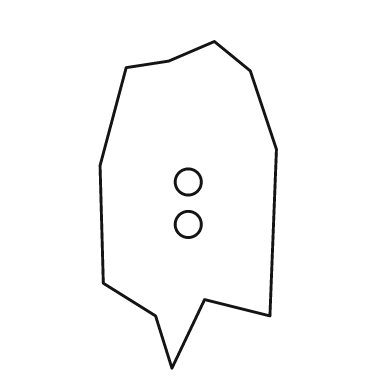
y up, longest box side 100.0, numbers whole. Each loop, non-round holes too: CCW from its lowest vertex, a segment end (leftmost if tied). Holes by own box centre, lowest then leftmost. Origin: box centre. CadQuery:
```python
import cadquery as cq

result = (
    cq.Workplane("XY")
    .moveTo(-5.0, -50.0)
    .lineTo(5.0, -29.0)
    .lineTo(25.0, -34.0)
    .lineTo(27.0, 17.0)
    .lineTo(19.0, 41.0)
    .lineTo(8.0, 50.0)
    .lineTo(-6.0, 44.0)
    .lineTo(-19.0, 42.0)
    .lineTo(-27.0, 12.0)
    .lineTo(-26.0, -24.0)
    .lineTo(-10.0, -34.0)
    .close()
    .moveTo(0.0, -6.0)
    .circle(4.0)
    .moveTo(0.0, 7.0)
    .circle(4.0)
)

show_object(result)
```